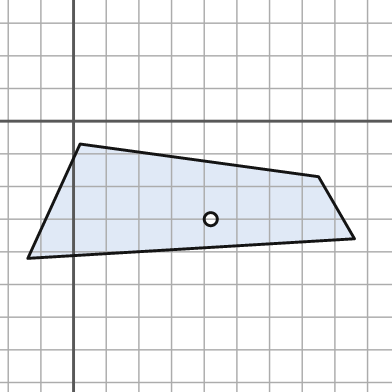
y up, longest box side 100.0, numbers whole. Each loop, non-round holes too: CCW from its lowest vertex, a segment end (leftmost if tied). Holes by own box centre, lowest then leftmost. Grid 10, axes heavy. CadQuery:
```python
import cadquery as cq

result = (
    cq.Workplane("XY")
    .moveTo(-14.0, -42.0)
    .lineTo(86.0, -36.0)
    .lineTo(75.0, -17.0)
    .lineTo(2.0, -7.0)
    .close()
    .moveTo(42.0, -30.0)
    .circle(2.0)
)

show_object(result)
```